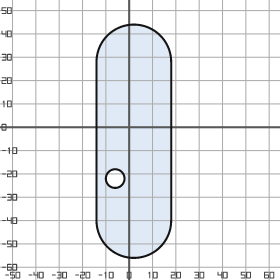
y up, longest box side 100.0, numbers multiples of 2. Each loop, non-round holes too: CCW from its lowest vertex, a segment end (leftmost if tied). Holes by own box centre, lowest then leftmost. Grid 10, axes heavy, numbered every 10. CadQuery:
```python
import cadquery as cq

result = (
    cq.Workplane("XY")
    .moveTo(-14.0, -40.0)
    .threePointArc((2.0, -56.0), (18.0, -40.0))
    .lineTo(18.0, 28.0)
    .threePointArc((2.0, 44.0), (-14.0, 28.0))
    .close()
    .moveTo(-6.0, -22.0)
    .circle(4.0)
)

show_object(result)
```